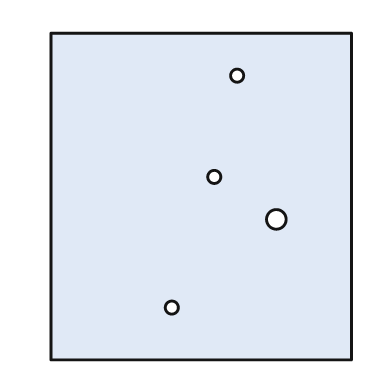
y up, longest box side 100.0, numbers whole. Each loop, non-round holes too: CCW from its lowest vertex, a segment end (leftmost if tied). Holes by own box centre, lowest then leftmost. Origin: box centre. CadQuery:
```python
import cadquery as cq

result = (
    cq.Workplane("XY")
    .moveTo(-46.0, -50.0)
    .lineTo(46.0, -50.0)
    .lineTo(46.0, 50.0)
    .lineTo(-46.0, 50.0)
    .close()
    .moveTo(-9.0, -34.0)
    .circle(2.0)
    .moveTo(23.0, -7.0)
    .circle(3.0)
    .moveTo(4.0, 6.0)
    .circle(2.0)
    .moveTo(11.0, 37.0)
    .circle(2.0)
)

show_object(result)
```